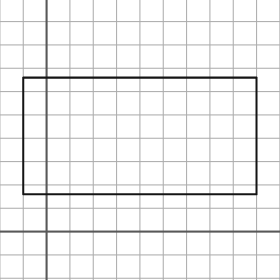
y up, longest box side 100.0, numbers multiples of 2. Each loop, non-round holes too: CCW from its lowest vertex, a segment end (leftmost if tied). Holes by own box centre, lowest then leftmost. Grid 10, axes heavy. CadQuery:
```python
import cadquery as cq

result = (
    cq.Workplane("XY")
    .moveTo(-10.0, 16.0)
    .lineTo(90.0, 16.0)
    .lineTo(90.0, 66.0)
    .lineTo(-10.0, 66.0)
    .close()
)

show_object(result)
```